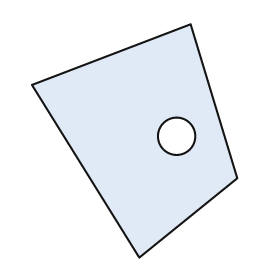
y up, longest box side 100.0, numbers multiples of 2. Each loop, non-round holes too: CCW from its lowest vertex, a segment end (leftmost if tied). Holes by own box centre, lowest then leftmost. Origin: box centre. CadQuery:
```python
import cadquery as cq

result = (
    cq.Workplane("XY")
    .moveTo(2.0, -50.0)
    .lineTo(44.0, -16.0)
    .lineTo(24.0, 50.0)
    .lineTo(-44.0, 24.0)
    .close()
    .moveTo(18.0, 2.0)
    .circle(8.0)
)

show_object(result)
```